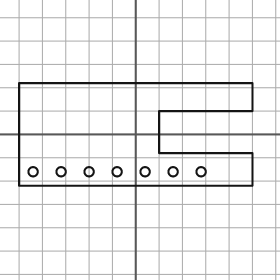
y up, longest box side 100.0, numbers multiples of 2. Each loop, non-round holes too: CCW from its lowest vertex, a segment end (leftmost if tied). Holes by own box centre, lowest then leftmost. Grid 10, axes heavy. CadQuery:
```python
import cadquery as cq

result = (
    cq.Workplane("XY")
    .moveTo(-50.0, -22.0)
    .lineTo(50.0, -22.0)
    .lineTo(50.0, -8.0)
    .lineTo(10.0, -8.0)
    .lineTo(10.0, 10.0)
    .lineTo(50.0, 10.0)
    .lineTo(50.0, 22.0)
    .lineTo(-50.0, 22.0)
    .close()
    .moveTo(-44.0, -16.0)
    .circle(2.0)
    .moveTo(-32.0, -16.0)
    .circle(2.0)
    .moveTo(-20.0, -16.0)
    .circle(2.0)
    .moveTo(-8.0, -16.0)
    .circle(2.0)
    .moveTo(4.0, -16.0)
    .circle(2.0)
    .moveTo(16.0, -16.0)
    .circle(2.0)
    .moveTo(28.0, -16.0)
    .circle(2.0)
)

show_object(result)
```